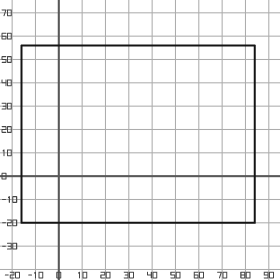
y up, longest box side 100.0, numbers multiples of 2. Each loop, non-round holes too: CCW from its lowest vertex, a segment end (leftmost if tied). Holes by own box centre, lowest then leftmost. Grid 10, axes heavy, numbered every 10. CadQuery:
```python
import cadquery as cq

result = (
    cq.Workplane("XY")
    .moveTo(-16.0, -20.0)
    .lineTo(84.0, -20.0)
    .lineTo(84.0, 56.0)
    .lineTo(-16.0, 56.0)
    .close()
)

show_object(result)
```